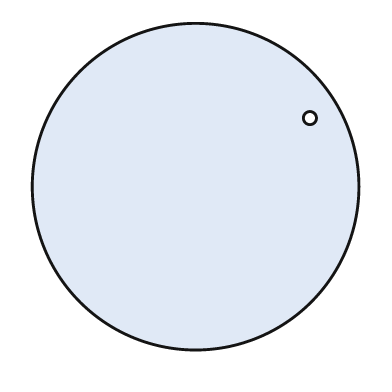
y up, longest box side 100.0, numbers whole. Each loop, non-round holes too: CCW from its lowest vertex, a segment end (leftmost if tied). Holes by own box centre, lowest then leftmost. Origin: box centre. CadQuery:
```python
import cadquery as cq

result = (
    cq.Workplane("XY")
    .moveTo(0.0, 0.0)
    .circle(50.0)
    .moveTo(35.0, 21.0)
    .circle(2.0)
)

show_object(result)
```